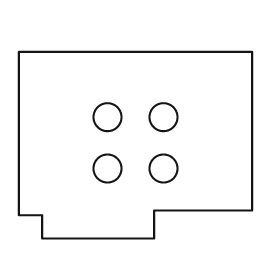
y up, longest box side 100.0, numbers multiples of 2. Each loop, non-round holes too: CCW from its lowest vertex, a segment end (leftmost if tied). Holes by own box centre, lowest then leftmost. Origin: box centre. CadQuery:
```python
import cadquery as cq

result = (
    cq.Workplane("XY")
    .moveTo(-40.0, -40.0)
    .lineTo(8.0, -40.0)
    .lineTo(8.0, -28.0)
    .lineTo(50.0, -28.0)
    .lineTo(50.0, 40.0)
    .lineTo(-50.0, 40.0)
    .lineTo(-50.0, -30.0)
    .lineTo(-40.0, -30.0)
    .close()
    .moveTo(-12.0, -10.0)
    .circle(6.0)
    .moveTo(12.0, -10.0)
    .circle(6.0)
    .moveTo(-12.0, 12.0)
    .circle(6.0)
    .moveTo(12.0, 12.0)
    .circle(6.0)
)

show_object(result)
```